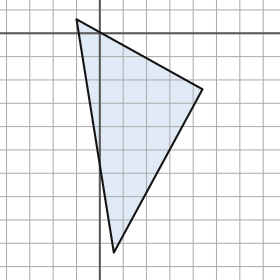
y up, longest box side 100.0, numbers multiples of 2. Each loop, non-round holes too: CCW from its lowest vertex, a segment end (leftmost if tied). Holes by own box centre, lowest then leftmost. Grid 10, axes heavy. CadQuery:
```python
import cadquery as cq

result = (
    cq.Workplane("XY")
    .moveTo(6.0, -94.0)
    .lineTo(44.0, -24.0)
    .lineTo(-10.0, 6.0)
    .close()
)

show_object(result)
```